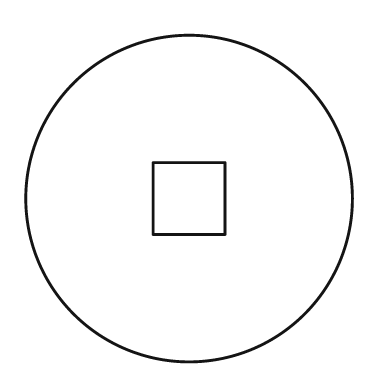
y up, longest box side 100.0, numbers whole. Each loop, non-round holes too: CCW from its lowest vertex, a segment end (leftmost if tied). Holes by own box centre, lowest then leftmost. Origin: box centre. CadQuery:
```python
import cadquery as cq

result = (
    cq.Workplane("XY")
    .moveTo(0.0, 0.0)
    .circle(50.0)
    .moveTo(-11.0, -11.0)
    .lineTo(11.0, -11.0)
    .lineTo(11.0, 11.0)
    .lineTo(-11.0, 11.0)
    .close()
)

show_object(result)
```